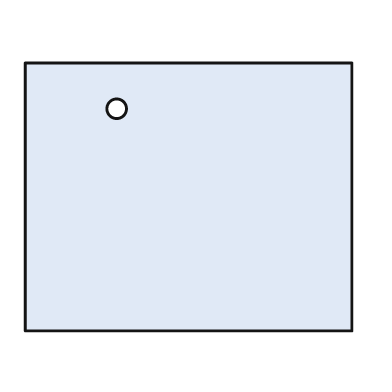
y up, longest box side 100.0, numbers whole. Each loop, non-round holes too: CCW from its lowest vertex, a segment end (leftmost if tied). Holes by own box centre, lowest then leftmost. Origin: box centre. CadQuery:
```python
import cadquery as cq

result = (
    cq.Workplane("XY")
    .moveTo(-50.0, -41.0)
    .lineTo(50.0, -41.0)
    .lineTo(50.0, 41.0)
    .lineTo(-50.0, 41.0)
    .close()
    .moveTo(-22.0, 27.0)
    .circle(3.0)
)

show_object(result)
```